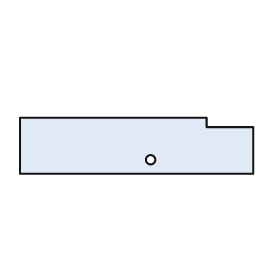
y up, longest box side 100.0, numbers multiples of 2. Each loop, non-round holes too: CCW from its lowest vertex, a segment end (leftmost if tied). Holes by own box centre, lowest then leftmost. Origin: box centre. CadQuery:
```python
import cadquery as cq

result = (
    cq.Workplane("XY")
    .moveTo(-50.0, -12.0)
    .lineTo(50.0, -12.0)
    .lineTo(50.0, 8.0)
    .lineTo(30.0, 8.0)
    .lineTo(30.0, 12.0)
    .lineTo(-50.0, 12.0)
    .close()
    .moveTo(6.0, -6.0)
    .circle(2.0)
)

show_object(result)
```